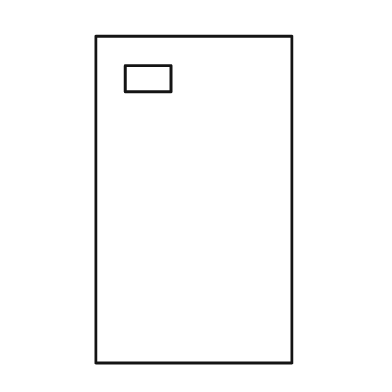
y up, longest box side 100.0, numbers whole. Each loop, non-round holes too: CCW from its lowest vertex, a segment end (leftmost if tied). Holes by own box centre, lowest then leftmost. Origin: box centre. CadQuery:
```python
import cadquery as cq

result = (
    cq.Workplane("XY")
    .moveTo(-30.0, -50.0)
    .lineTo(30.0, -50.0)
    .lineTo(30.0, 50.0)
    .lineTo(-30.0, 50.0)
    .close()
    .moveTo(-21.0, 33.0)
    .lineTo(-7.0, 33.0)
    .lineTo(-7.0, 41.0)
    .lineTo(-21.0, 41.0)
    .close()
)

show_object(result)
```